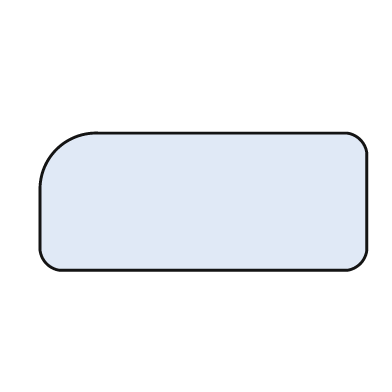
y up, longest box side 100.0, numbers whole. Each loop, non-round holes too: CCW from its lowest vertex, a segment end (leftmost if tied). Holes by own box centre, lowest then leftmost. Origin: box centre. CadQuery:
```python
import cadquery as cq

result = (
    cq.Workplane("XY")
    .moveTo(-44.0, -21.0)
    .lineTo(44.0, -21.0)
    .threePointArc((48.0, -19.0), (50.0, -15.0))
    .lineTo(50.0, 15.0)
    .threePointArc((48.0, 19.0), (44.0, 21.0))
    .lineTo(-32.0, 21.0)
    .threePointArc((-45.0, 16.0), (-50.0, 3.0))
    .lineTo(-50.0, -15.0)
    .threePointArc((-48.0, -19.0), (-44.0, -21.0))
    .close()
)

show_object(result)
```